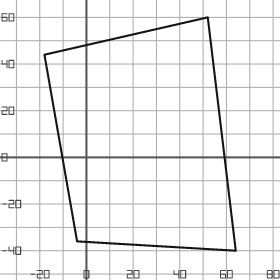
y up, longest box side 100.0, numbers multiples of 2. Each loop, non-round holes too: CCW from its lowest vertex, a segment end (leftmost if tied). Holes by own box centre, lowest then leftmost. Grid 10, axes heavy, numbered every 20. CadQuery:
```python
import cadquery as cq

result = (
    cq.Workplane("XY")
    .moveTo(64.0, -40.0)
    .lineTo(52.0, 60.0)
    .lineTo(-18.0, 44.0)
    .lineTo(-4.0, -36.0)
    .close()
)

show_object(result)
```